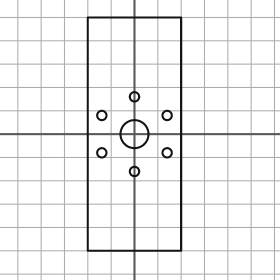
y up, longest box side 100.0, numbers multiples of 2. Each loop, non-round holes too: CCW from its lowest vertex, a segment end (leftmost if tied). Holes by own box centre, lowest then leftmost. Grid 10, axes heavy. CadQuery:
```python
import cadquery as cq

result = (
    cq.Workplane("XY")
    .moveTo(-20.0, -50.0)
    .lineTo(20.0, -50.0)
    .lineTo(20.0, 50.0)
    .lineTo(-20.0, 50.0)
    .close()
    .moveTo(0.0, -16.0)
    .circle(2.0)
    .moveTo(-14.0, -8.0)
    .circle(2.0)
    .moveTo(14.0, -8.0)
    .circle(2.0)
    .moveTo(0.0, 0.0)
    .circle(6.0)
    .moveTo(-14.0, 8.0)
    .circle(2.0)
    .moveTo(14.0, 8.0)
    .circle(2.0)
    .moveTo(0.0, 16.0)
    .circle(2.0)
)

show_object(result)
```